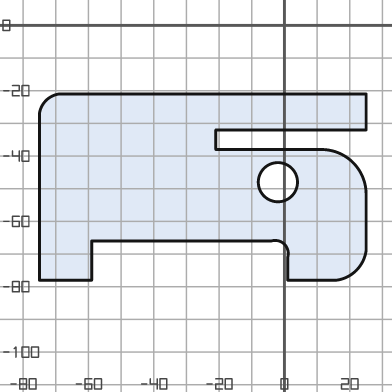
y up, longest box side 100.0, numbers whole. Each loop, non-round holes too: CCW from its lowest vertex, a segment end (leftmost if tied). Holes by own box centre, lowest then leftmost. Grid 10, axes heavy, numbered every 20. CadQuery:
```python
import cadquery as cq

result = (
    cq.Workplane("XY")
    .moveTo(-75.0, -78.0)
    .lineTo(-59.0, -78.0)
    .lineTo(-59.0, -66.0)
    .lineTo(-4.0, -66.0)
    .threePointArc((0.0, -67.0), (1.0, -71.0))
    .lineTo(1.0, -78.0)
    .lineTo(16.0, -78.0)
    .threePointArc((22.0, -75.0), (25.0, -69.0))
    .lineTo(25.0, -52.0)
    .threePointArc((21.0, -42.0), (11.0, -38.0))
    .lineTo(-21.0, -38.0)
    .lineTo(-21.0, -32.0)
    .lineTo(25.0, -32.0)
    .lineTo(25.0, -21.0)
    .lineTo(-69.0, -21.0)
    .threePointArc((-73.0, -23.0), (-75.0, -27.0))
    .close()
    .moveTo(-2.0, -48.0)
    .circle(6.0)
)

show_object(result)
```